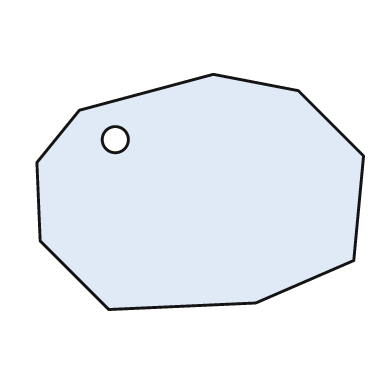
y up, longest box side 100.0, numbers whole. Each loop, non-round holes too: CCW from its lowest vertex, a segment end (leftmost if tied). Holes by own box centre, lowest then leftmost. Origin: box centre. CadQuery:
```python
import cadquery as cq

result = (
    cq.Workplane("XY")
    .moveTo(-28.0, -36.0)
    .lineTo(17.0, -34.0)
    .lineTo(47.0, -21.0)
    .lineTo(50.0, 11.0)
    .lineTo(30.0, 31.0)
    .lineTo(4.0, 36.0)
    .lineTo(-37.0, 25.0)
    .lineTo(-50.0, 9.0)
    .lineTo(-49.0, -15.0)
    .close()
    .moveTo(-26.0, 16.0)
    .circle(4.0)
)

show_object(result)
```